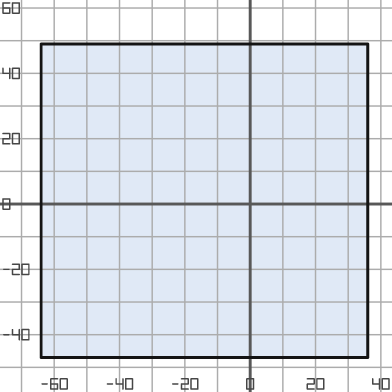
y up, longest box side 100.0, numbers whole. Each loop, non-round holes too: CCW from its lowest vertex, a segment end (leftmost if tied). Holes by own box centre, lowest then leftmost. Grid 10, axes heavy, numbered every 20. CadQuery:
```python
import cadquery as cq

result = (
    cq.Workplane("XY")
    .moveTo(-64.0, -47.0)
    .lineTo(36.0, -47.0)
    .lineTo(36.0, 49.0)
    .lineTo(-64.0, 49.0)
    .close()
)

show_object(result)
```